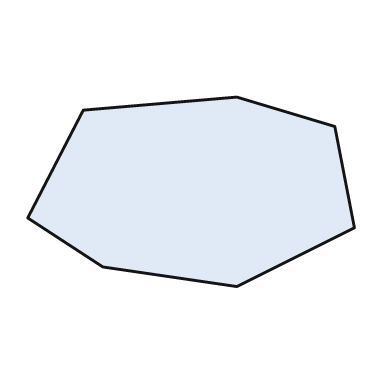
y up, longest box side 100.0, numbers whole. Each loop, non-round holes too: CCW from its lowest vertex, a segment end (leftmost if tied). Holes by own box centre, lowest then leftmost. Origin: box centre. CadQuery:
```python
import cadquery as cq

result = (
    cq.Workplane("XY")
    .moveTo(14.0, -29.0)
    .lineTo(50.0, -11.0)
    .lineTo(44.0, 20.0)
    .lineTo(14.0, 29.0)
    .lineTo(-33.0, 25.0)
    .lineTo(-50.0, -8.0)
    .lineTo(-27.0, -23.0)
    .close()
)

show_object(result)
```